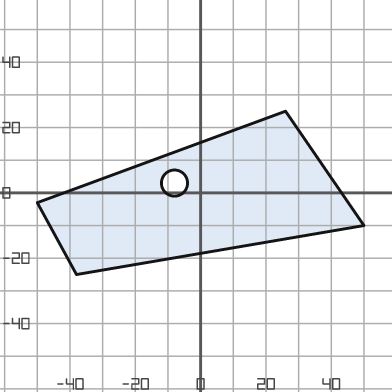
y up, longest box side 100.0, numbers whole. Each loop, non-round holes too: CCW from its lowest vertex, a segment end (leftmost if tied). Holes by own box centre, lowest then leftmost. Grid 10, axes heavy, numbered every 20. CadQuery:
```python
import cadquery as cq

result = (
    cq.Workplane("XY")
    .moveTo(-38.0, -25.0)
    .lineTo(50.0, -10.0)
    .lineTo(26.0, 25.0)
    .lineTo(-50.0, -3.0)
    .close()
    .moveTo(-8.0, 3.0)
    .circle(4.0)
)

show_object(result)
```